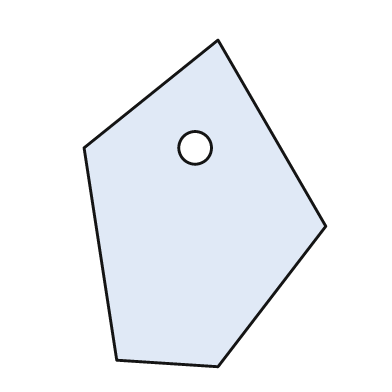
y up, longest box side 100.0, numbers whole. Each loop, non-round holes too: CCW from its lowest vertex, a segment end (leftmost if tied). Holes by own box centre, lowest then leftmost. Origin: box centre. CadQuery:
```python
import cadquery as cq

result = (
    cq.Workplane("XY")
    .moveTo(4.0, -50.0)
    .lineTo(37.0, -7.0)
    .lineTo(4.0, 50.0)
    .lineTo(-37.0, 17.0)
    .lineTo(-27.0, -48.0)
    .close()
    .moveTo(-3.0, 17.0)
    .circle(5.0)
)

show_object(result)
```